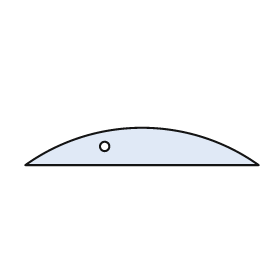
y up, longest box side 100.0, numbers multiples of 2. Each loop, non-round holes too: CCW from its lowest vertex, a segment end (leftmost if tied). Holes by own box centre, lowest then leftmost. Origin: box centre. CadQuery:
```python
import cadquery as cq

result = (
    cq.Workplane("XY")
    .moveTo(-50.0, -8.0)
    .lineTo(50.0, -8.0)
    .threePointArc((0.0, 8.0), (-50.0, -8.0))
    .close()
    .moveTo(-16.0, 0.0)
    .circle(2.0)
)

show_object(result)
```